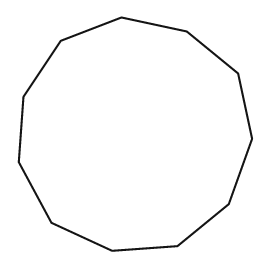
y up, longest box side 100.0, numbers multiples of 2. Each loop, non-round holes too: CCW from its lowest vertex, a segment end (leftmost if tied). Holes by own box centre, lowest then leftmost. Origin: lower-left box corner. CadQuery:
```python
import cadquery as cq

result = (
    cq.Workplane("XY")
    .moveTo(40.0, 0.0)
    .lineTo(68.0, 2.0)
    .lineTo(90.0, 20.0)
    .lineTo(100.0, 48.0)
    .lineTo(94.0, 76.0)
    .lineTo(72.0, 94.0)
    .lineTo(44.0, 100.0)
    .lineTo(18.0, 90.0)
    .lineTo(2.0, 66.0)
    .lineTo(0.0, 38.0)
    .lineTo(14.0, 12.0)
    .close()
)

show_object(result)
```